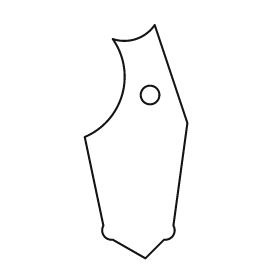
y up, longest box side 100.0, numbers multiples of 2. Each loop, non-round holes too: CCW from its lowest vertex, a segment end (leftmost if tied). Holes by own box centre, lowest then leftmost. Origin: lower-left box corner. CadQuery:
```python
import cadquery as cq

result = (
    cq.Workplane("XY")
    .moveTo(26.0, 0.0)
    .lineTo(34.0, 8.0)
    .threePointArc((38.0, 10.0), (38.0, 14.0))
    .lineTo(44.0, 58.0)
    .lineTo(30.0, 100.0)
    .threePointArc((22.0, 94.0), (12.0, 94.0))
    .threePointArc((16.0, 70.0), (0.0, 52.0))
    .lineTo(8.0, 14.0)
    .threePointArc((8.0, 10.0), (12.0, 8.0))
    .close()
    .moveTo(28.0, 70.0)
    .circle(4.0)
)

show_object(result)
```